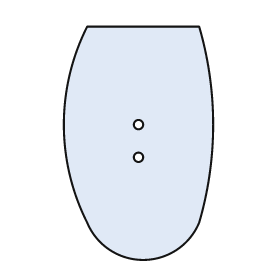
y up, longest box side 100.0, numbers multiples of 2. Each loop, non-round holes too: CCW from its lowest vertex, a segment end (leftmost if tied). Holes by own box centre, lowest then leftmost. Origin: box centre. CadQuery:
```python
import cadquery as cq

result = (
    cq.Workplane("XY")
    .moveTo(-22.0, -34.0)
    .threePointArc((2.0, -50.0), (26.0, -34.0))
    .threePointArc((32.0, 8.0), (26.0, 50.0))
    .lineTo(-22.0, 50.0)
    .threePointArc((-32.0, 8.0), (-22.0, -34.0))
    .close()
    .moveTo(0.0, -6.0)
    .circle(2.0)
    .moveTo(0.0, 8.0)
    .circle(2.0)
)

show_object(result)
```